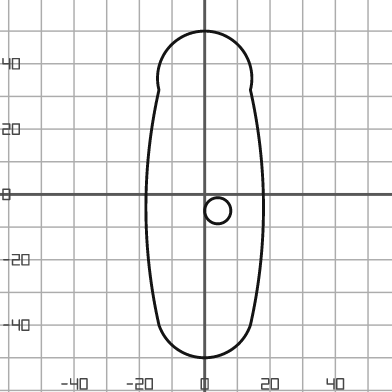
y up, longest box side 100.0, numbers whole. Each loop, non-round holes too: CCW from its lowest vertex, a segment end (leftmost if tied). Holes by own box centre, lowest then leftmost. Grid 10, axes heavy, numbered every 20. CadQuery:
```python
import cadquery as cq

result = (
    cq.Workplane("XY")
    .moveTo(-14.0, -40.0)
    .threePointArc((0.0, -50.0), (14.0, -40.0))
    .threePointArc((18.0, -4.0), (14.0, 32.0))
    .threePointArc((0.0, 50.0), (-14.0, 32.0))
    .threePointArc((-18.0, -4.0), (-14.0, -40.0))
    .close()
    .moveTo(4.0, -5.0)
    .circle(4.0)
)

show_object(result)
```